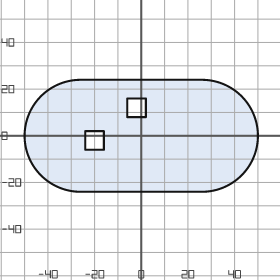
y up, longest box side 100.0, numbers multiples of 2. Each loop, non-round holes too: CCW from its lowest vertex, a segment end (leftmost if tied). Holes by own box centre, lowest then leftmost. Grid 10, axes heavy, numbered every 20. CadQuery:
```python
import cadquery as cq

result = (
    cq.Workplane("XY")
    .moveTo(-26.0, -24.0)
    .lineTo(26.0, -24.0)
    .threePointArc((50.0, 0.0), (26.0, 24.0))
    .lineTo(-26.0, 24.0)
    .threePointArc((-50.0, 0.0), (-26.0, -24.0))
    .close()
    .moveTo(-24.0, -6.0)
    .lineTo(-16.0, -6.0)
    .lineTo(-16.0, 2.0)
    .lineTo(-24.0, 2.0)
    .close()
    .moveTo(-6.0, 8.0)
    .lineTo(2.0, 8.0)
    .lineTo(2.0, 16.0)
    .lineTo(-6.0, 16.0)
    .close()
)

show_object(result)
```